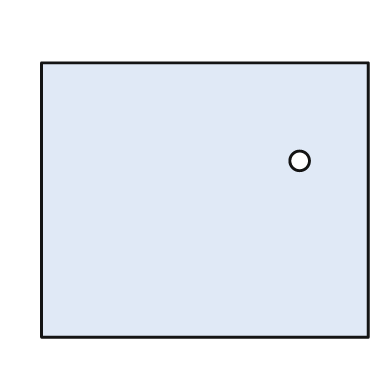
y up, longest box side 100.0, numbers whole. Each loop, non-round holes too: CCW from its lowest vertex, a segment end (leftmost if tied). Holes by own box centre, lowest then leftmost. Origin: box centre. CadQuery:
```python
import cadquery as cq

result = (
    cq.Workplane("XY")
    .moveTo(-50.0, -42.0)
    .lineTo(50.0, -42.0)
    .lineTo(50.0, 42.0)
    .lineTo(-50.0, 42.0)
    .close()
    .moveTo(29.0, 12.0)
    .circle(3.0)
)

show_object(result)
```